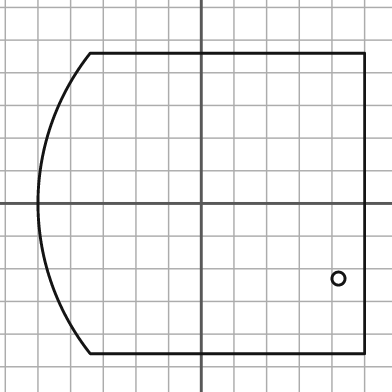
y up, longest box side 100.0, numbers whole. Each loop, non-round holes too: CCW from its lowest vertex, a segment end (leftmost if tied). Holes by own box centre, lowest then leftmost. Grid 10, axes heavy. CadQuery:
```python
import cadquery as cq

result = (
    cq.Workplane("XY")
    .moveTo(-34.0, -46.0)
    .lineTo(50.0, -46.0)
    .lineTo(50.0, 46.0)
    .lineTo(-34.0, 46.0)
    .threePointArc((-50.0, 0.0), (-34.0, -46.0))
    .close()
    .moveTo(42.0, -23.0)
    .circle(2.0)
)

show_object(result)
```